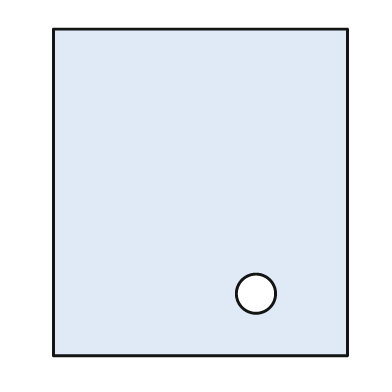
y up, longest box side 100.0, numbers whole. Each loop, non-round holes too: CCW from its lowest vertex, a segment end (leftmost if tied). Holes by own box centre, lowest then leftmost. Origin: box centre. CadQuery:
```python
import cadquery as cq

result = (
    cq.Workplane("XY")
    .moveTo(-45.0, -50.0)
    .lineTo(45.0, -50.0)
    .lineTo(45.0, 50.0)
    .lineTo(-45.0, 50.0)
    .close()
    .moveTo(17.0, -31.0)
    .circle(6.0)
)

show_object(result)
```